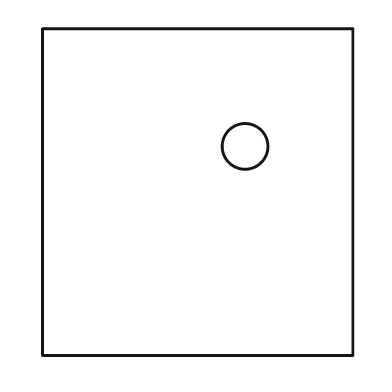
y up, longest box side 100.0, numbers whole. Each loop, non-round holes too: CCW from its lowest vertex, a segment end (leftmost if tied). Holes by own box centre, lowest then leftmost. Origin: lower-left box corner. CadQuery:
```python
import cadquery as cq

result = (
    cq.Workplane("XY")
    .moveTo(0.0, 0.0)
    .lineTo(95.0, 0.0)
    .lineTo(95.0, 100.0)
    .lineTo(0.0, 100.0)
    .close()
    .moveTo(62.0, 64.0)
    .circle(7.0)
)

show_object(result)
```